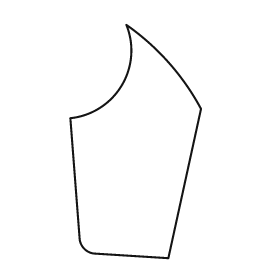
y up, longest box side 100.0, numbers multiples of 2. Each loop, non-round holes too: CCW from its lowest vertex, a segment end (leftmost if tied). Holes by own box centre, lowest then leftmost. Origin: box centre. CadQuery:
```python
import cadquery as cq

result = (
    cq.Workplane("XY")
    .moveTo(14.0, -50.0)
    .lineTo(28.0, 14.0)
    .threePointArc((14.0, 34.0), (-4.0, 50.0))
    .threePointArc((-6.0, 24.0), (-28.0, 10.0))
    .lineTo(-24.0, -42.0)
    .threePointArc((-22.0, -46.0), (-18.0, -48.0))
    .close()
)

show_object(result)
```